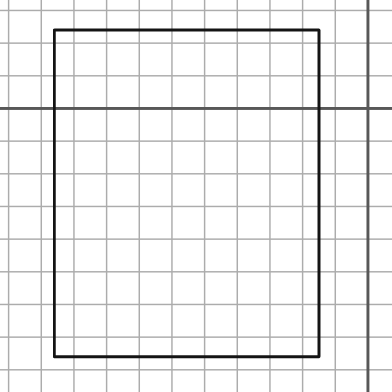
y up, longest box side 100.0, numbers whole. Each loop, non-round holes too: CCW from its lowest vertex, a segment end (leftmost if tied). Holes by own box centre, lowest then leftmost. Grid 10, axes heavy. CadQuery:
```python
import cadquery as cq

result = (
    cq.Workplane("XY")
    .moveTo(-96.0, -76.0)
    .lineTo(-15.0, -76.0)
    .lineTo(-15.0, 24.0)
    .lineTo(-96.0, 24.0)
    .close()
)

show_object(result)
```